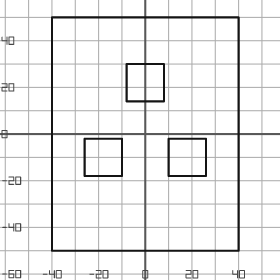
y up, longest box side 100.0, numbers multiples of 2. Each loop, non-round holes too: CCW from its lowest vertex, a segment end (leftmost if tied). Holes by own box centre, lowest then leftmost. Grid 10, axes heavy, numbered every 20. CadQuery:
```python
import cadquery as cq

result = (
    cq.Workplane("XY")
    .moveTo(-40.0, -50.0)
    .lineTo(40.0, -50.0)
    .lineTo(40.0, 50.0)
    .lineTo(-40.0, 50.0)
    .close()
    .moveTo(-26.0, -18.0)
    .lineTo(-10.0, -18.0)
    .lineTo(-10.0, -2.0)
    .lineTo(-26.0, -2.0)
    .close()
    .moveTo(10.0, -18.0)
    .lineTo(26.0, -18.0)
    .lineTo(26.0, -2.0)
    .lineTo(10.0, -2.0)
    .close()
    .moveTo(-8.0, 14.0)
    .lineTo(8.0, 14.0)
    .lineTo(8.0, 30.0)
    .lineTo(-8.0, 30.0)
    .close()
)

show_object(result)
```